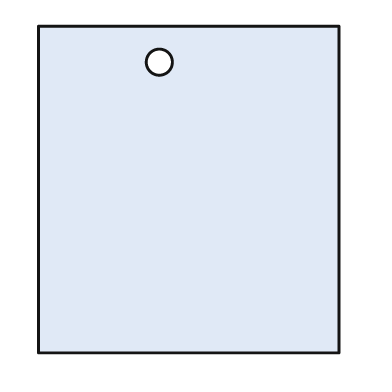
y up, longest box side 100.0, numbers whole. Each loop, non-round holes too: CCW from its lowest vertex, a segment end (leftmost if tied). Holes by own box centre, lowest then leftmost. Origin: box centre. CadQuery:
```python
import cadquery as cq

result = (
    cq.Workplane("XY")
    .moveTo(-46.0, -50.0)
    .lineTo(46.0, -50.0)
    .lineTo(46.0, 50.0)
    .lineTo(-46.0, 50.0)
    .close()
    .moveTo(-9.0, 39.0)
    .circle(4.0)
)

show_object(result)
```